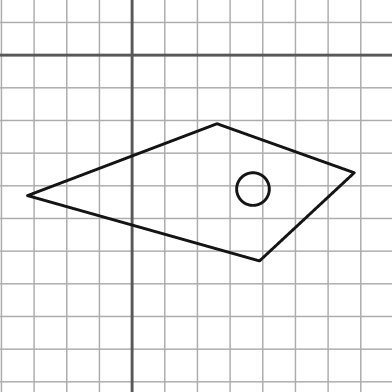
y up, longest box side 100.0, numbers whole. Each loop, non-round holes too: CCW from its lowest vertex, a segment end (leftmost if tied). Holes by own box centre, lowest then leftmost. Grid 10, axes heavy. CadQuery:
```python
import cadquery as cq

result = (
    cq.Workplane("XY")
    .moveTo(39.0, -63.0)
    .lineTo(68.0, -36.0)
    .lineTo(26.0, -21.0)
    .lineTo(-32.0, -43.0)
    .close()
    .moveTo(37.0, -41.0)
    .circle(5.0)
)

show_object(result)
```